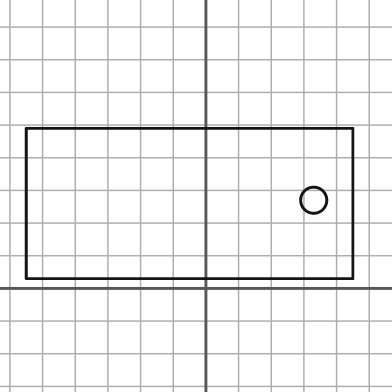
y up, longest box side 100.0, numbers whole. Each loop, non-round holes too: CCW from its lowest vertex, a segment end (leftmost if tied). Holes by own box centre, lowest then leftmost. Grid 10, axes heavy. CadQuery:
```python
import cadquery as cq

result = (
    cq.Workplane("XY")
    .moveTo(-55.0, 3.0)
    .lineTo(45.0, 3.0)
    .lineTo(45.0, 49.0)
    .lineTo(-55.0, 49.0)
    .close()
    .moveTo(33.0, 27.0)
    .circle(4.0)
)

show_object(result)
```